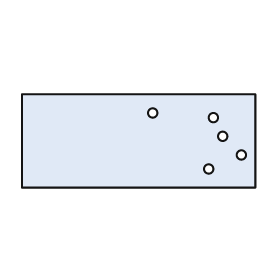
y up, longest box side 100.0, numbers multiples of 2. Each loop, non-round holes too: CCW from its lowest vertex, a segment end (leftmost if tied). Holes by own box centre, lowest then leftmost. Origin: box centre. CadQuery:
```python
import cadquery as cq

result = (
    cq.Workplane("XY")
    .moveTo(-50.0, -20.0)
    .lineTo(50.0, -20.0)
    .lineTo(50.0, 20.0)
    .lineTo(-50.0, 20.0)
    .close()
    .moveTo(30.0, -12.0)
    .circle(2.0)
    .moveTo(44.0, -6.0)
    .circle(2.0)
    .moveTo(36.0, 2.0)
    .circle(2.0)
    .moveTo(32.0, 10.0)
    .circle(2.0)
    .moveTo(6.0, 12.0)
    .circle(2.0)
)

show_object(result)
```